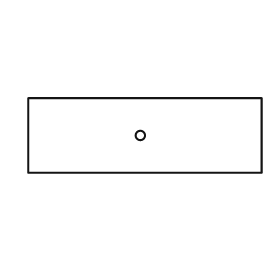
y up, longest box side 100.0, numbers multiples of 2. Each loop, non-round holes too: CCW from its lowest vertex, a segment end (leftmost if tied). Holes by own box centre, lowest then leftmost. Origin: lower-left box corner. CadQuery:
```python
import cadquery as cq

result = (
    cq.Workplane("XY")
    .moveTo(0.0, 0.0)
    .lineTo(100.0, 0.0)
    .lineTo(100.0, 32.0)
    .lineTo(0.0, 32.0)
    .close()
    .moveTo(48.0, 16.0)
    .circle(2.0)
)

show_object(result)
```